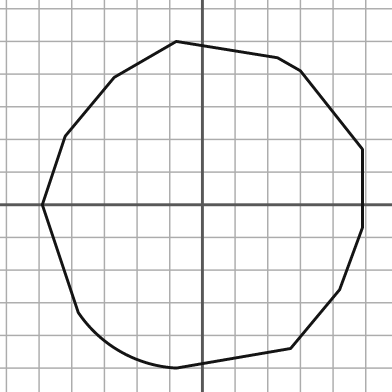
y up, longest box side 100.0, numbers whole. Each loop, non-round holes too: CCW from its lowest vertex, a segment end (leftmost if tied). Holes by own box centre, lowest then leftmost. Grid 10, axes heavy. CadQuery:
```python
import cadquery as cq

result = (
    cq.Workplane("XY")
    .moveTo(-8.0, -50.0)
    .lineTo(27.0, -44.0)
    .lineTo(42.0, -26.0)
    .lineTo(49.0, -7.0)
    .lineTo(49.0, 17.0)
    .lineTo(30.0, 41.0)
    .lineTo(23.0, 45.0)
    .lineTo(-8.0, 50.0)
    .lineTo(-27.0, 39.0)
    .lineTo(-42.0, 21.0)
    .lineTo(-49.0, 0.0)
    .lineTo(-38.0, -33.0)
    .threePointArc((-25.0, -45.0), (-8.0, -50.0))
    .close()
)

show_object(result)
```